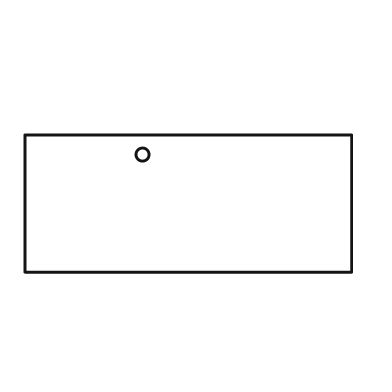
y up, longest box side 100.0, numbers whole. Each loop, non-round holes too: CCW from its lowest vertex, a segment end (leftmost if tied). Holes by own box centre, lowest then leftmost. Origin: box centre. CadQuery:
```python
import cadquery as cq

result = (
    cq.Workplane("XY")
    .moveTo(-50.0, -21.0)
    .lineTo(50.0, -21.0)
    .lineTo(50.0, 21.0)
    .lineTo(-50.0, 21.0)
    .close()
    .moveTo(-14.0, 15.0)
    .circle(2.0)
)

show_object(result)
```